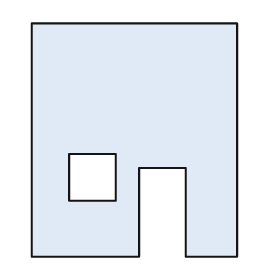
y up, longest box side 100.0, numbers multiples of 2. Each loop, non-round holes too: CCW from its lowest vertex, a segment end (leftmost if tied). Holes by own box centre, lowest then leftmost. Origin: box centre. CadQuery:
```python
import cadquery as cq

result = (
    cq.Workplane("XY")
    .moveTo(-44.0, -50.0)
    .lineTo(2.0, -50.0)
    .lineTo(2.0, -12.0)
    .lineTo(22.0, -12.0)
    .lineTo(22.0, -50.0)
    .lineTo(44.0, -50.0)
    .lineTo(44.0, 50.0)
    .lineTo(-44.0, 50.0)
    .close()
    .moveTo(-28.0, -26.0)
    .lineTo(-8.0, -26.0)
    .lineTo(-8.0, -6.0)
    .lineTo(-28.0, -6.0)
    .close()
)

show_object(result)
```